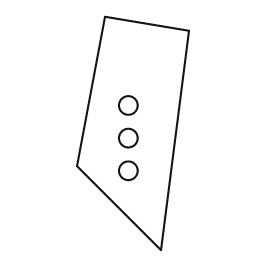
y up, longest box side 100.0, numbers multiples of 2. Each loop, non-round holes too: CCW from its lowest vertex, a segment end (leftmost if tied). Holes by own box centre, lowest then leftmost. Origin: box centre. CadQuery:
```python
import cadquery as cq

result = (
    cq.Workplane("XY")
    .moveTo(12.0, -50.0)
    .lineTo(24.0, 44.0)
    .lineTo(-12.0, 50.0)
    .lineTo(-24.0, -14.0)
    .close()
    .moveTo(-2.0, -16.0)
    .circle(4.0)
    .moveTo(-2.0, -2.0)
    .circle(4.0)
    .moveTo(-2.0, 12.0)
    .circle(4.0)
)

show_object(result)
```